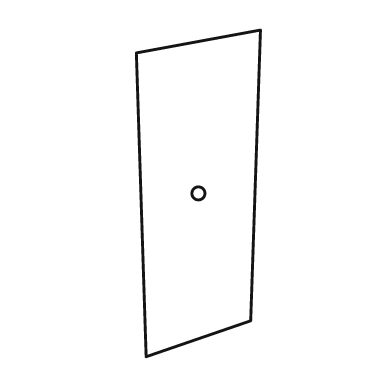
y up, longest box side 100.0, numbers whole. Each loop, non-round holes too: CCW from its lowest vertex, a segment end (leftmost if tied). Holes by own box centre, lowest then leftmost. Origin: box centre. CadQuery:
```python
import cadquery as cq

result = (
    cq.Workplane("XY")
    .moveTo(-16.0, -50.0)
    .lineTo(16.0, -39.0)
    .lineTo(19.0, 50.0)
    .lineTo(-19.0, 43.0)
    .close()
    .moveTo(0.0, 0.0)
    .circle(2.0)
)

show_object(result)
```